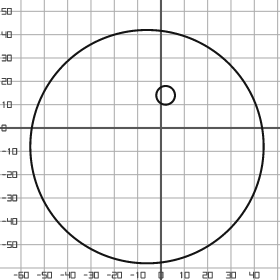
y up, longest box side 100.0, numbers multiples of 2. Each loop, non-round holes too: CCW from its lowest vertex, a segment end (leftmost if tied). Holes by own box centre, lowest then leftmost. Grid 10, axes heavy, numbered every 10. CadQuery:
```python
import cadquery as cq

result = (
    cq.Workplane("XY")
    .moveTo(-6.0, -8.0)
    .circle(50.0)
    .moveTo(2.0, 14.0)
    .circle(4.0)
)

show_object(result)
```